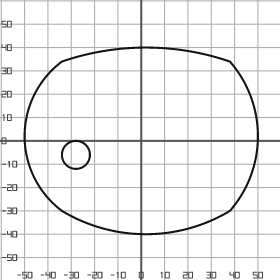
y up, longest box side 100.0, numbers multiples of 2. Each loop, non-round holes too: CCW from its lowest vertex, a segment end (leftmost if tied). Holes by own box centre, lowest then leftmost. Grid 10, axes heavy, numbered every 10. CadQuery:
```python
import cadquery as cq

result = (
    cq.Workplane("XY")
    .moveTo(-34.0, -30.0)
    .threePointArc((2.0, -40.0), (38.0, -30.0))
    .threePointArc((50.0, 2.0), (38.0, 34.0))
    .threePointArc((2.0, 40.0), (-34.0, 34.0))
    .threePointArc((-50.0, 2.0), (-34.0, -30.0))
    .close()
    .moveTo(-28.0, -6.0)
    .circle(6.0)
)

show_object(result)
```